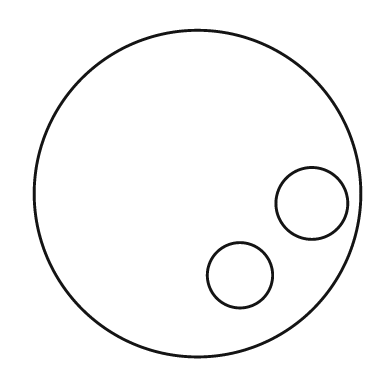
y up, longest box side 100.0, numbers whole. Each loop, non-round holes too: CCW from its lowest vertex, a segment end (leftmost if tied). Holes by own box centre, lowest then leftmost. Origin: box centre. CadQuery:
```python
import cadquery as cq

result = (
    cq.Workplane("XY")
    .moveTo(0.0, 0.0)
    .circle(50.0)
    .moveTo(13.0, -25.0)
    .circle(10.0)
    .moveTo(35.0, -3.0)
    .circle(11.0)
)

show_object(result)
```